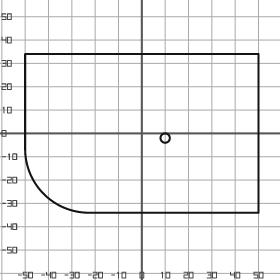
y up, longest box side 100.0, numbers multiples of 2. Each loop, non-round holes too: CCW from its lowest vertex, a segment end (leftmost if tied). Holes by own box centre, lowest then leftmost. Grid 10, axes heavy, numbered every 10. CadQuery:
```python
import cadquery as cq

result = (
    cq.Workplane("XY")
    .moveTo(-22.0, -34.0)
    .lineTo(50.0, -34.0)
    .lineTo(50.0, 34.0)
    .lineTo(-50.0, 34.0)
    .lineTo(-50.0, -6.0)
    .threePointArc((-42.0, -26.0), (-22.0, -34.0))
    .close()
    .moveTo(10.0, -2.0)
    .circle(2.0)
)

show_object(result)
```